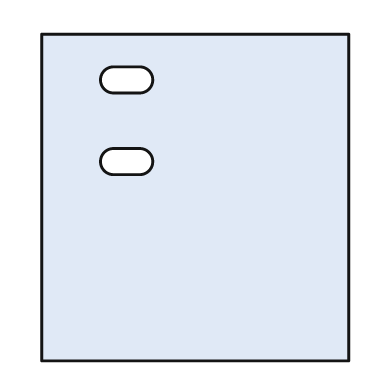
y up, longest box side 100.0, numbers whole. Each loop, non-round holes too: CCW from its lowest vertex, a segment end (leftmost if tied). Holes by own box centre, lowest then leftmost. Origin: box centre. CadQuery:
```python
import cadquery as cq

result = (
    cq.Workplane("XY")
    .moveTo(-47.0, -50.0)
    .lineTo(47.0, -50.0)
    .lineTo(47.0, 50.0)
    .lineTo(-47.0, 50.0)
    .close()
    .moveTo(-25.0, 7.0)
    .lineTo(-17.0, 7.0)
    .threePointArc((-13.0, 11.0), (-17.0, 15.0))
    .lineTo(-25.0, 15.0)
    .threePointArc((-29.0, 11.0), (-25.0, 7.0))
    .close()
    .moveTo(-25.0, 32.0)
    .lineTo(-17.0, 32.0)
    .threePointArc((-13.0, 36.0), (-17.0, 40.0))
    .lineTo(-25.0, 40.0)
    .threePointArc((-29.0, 36.0), (-25.0, 32.0))
    .close()
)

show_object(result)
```